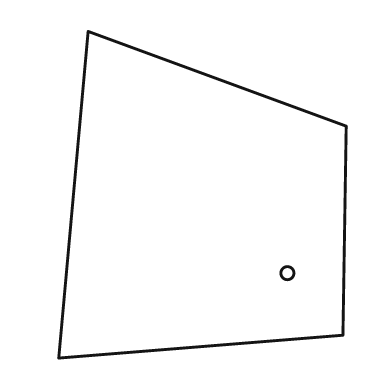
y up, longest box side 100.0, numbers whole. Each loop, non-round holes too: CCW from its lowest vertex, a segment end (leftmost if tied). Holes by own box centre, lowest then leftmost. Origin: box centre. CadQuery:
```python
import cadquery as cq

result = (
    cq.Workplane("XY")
    .moveTo(-44.0, -50.0)
    .lineTo(43.0, -43.0)
    .lineTo(44.0, 21.0)
    .lineTo(-35.0, 50.0)
    .close()
    .moveTo(26.0, -24.0)
    .circle(2.0)
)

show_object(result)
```